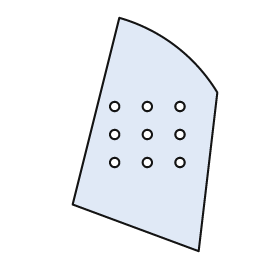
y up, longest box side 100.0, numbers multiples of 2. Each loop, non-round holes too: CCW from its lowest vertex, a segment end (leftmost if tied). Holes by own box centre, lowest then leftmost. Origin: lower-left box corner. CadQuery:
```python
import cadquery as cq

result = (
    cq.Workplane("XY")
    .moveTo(54.0, 0.0)
    .lineTo(62.0, 68.0)
    .threePointArc((44.0, 88.0), (20.0, 100.0))
    .lineTo(0.0, 20.0)
    .close()
    .moveTo(18.0, 38.0)
    .circle(2.0)
    .moveTo(32.0, 38.0)
    .circle(2.0)
    .moveTo(46.0, 38.0)
    .circle(2.0)
    .moveTo(18.0, 50.0)
    .circle(2.0)
    .moveTo(32.0, 50.0)
    .circle(2.0)
    .moveTo(46.0, 50.0)
    .circle(2.0)
    .moveTo(18.0, 62.0)
    .circle(2.0)
    .moveTo(32.0, 62.0)
    .circle(2.0)
    .moveTo(46.0, 62.0)
    .circle(2.0)
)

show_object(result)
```